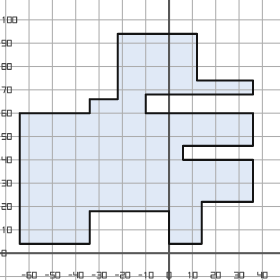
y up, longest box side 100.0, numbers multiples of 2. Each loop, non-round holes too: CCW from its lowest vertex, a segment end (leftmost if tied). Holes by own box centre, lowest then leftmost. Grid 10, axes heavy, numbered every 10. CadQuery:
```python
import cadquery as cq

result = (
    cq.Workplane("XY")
    .moveTo(-64.0, 4.0)
    .lineTo(-34.0, 4.0)
    .lineTo(-34.0, 18.0)
    .lineTo(0.0, 18.0)
    .lineTo(0.0, 4.0)
    .lineTo(14.0, 4.0)
    .lineTo(14.0, 22.0)
    .lineTo(36.0, 22.0)
    .lineTo(36.0, 40.0)
    .lineTo(6.0, 40.0)
    .lineTo(6.0, 46.0)
    .lineTo(36.0, 46.0)
    .lineTo(36.0, 60.0)
    .lineTo(-10.0, 60.0)
    .lineTo(-10.0, 68.0)
    .lineTo(36.0, 68.0)
    .lineTo(36.0, 74.0)
    .lineTo(12.0, 74.0)
    .lineTo(12.0, 94.0)
    .lineTo(-22.0, 94.0)
    .lineTo(-22.0, 66.0)
    .lineTo(-34.0, 66.0)
    .lineTo(-34.0, 60.0)
    .lineTo(-64.0, 60.0)
    .close()
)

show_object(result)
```